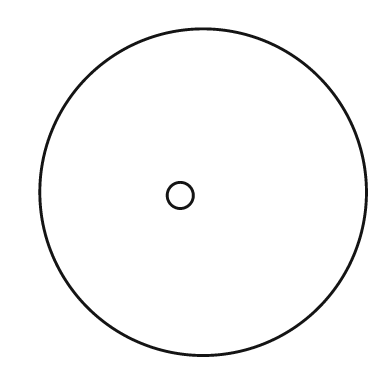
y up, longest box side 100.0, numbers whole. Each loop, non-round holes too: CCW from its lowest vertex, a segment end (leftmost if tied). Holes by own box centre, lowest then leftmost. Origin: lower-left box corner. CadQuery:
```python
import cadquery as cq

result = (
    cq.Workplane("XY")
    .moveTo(50.0, 50.0)
    .circle(50.0)
    .moveTo(43.0, 49.0)
    .circle(4.0)
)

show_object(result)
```